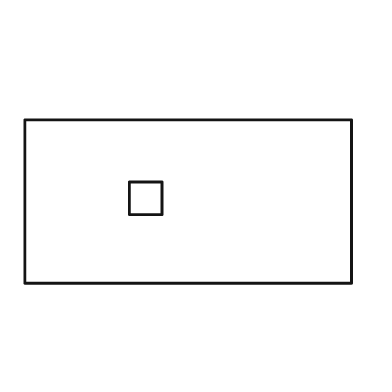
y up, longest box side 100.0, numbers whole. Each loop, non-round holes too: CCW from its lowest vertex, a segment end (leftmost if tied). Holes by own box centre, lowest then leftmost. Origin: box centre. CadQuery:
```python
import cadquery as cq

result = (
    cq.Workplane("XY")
    .moveTo(-50.0, -25.0)
    .lineTo(50.0, -25.0)
    .lineTo(50.0, 25.0)
    .lineTo(-50.0, 25.0)
    .close()
    .moveTo(-18.0, -4.0)
    .lineTo(-8.0, -4.0)
    .lineTo(-8.0, 6.0)
    .lineTo(-18.0, 6.0)
    .close()
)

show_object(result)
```